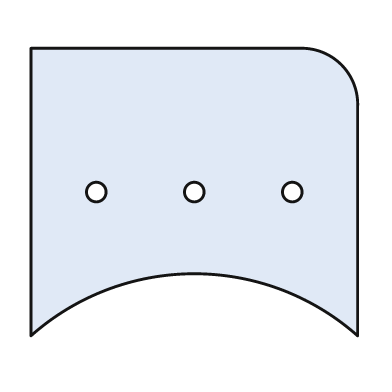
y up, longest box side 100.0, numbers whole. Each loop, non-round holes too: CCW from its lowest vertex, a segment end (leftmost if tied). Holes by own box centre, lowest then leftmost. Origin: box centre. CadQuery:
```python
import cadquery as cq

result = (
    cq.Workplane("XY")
    .moveTo(-50.0, -44.0)
    .threePointArc((0.0, -25.0), (50.0, -44.0))
    .lineTo(50.0, 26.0)
    .threePointArc((45.0, 39.0), (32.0, 44.0))
    .lineTo(-50.0, 44.0)
    .close()
    .moveTo(-30.0, 0.0)
    .circle(3.0)
    .moveTo(0.0, 0.0)
    .circle(3.0)
    .moveTo(30.0, 0.0)
    .circle(3.0)
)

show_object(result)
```